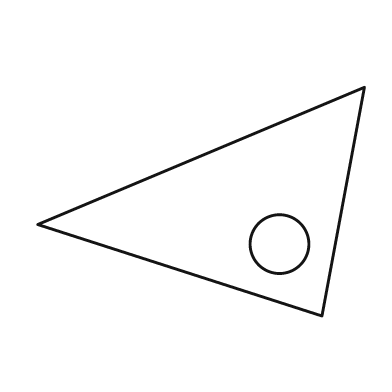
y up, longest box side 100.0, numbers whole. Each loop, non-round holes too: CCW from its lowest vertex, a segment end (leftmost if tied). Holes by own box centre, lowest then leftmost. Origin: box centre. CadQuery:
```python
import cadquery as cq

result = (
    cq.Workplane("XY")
    .moveTo(37.0, -35.0)
    .lineTo(50.0, 35.0)
    .lineTo(-50.0, -7.0)
    .close()
    .moveTo(24.0, -13.0)
    .circle(9.0)
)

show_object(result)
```